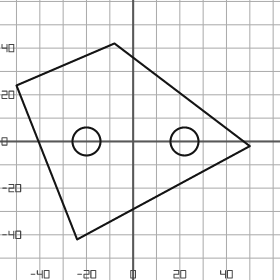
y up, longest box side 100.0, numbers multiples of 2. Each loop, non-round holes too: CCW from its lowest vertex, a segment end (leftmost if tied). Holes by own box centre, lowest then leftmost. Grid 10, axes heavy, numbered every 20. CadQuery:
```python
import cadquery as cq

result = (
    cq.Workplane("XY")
    .moveTo(-24.0, -42.0)
    .lineTo(50.0, -2.0)
    .lineTo(-8.0, 42.0)
    .lineTo(-50.0, 24.0)
    .close()
    .moveTo(-20.0, 0.0)
    .circle(6.0)
    .moveTo(22.0, 0.0)
    .circle(6.0)
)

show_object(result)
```